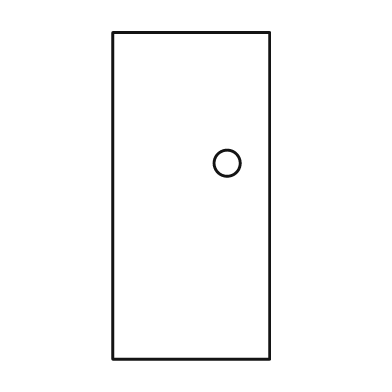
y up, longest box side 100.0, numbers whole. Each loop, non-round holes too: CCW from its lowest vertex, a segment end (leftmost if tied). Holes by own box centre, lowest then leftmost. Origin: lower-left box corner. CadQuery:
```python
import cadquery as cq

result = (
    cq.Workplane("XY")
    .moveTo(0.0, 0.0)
    .lineTo(48.0, 0.0)
    .lineTo(48.0, 100.0)
    .lineTo(0.0, 100.0)
    .close()
    .moveTo(35.0, 60.0)
    .circle(4.0)
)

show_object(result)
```